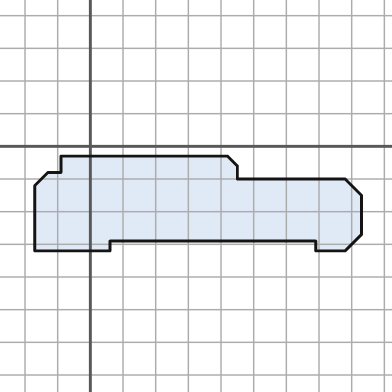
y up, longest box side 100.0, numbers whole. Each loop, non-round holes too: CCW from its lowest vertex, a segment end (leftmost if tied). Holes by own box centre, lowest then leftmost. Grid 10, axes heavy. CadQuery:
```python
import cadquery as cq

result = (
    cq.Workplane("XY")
    .moveTo(-17.0, -32.0)
    .lineTo(6.0, -32.0)
    .lineTo(6.0, -29.0)
    .lineTo(69.0, -29.0)
    .lineTo(69.0, -32.0)
    .lineTo(78.0, -32.0)
    .lineTo(83.0, -27.0)
    .lineTo(83.0, -15.0)
    .lineTo(78.0, -10.0)
    .lineTo(45.0, -10.0)
    .lineTo(45.0, -6.0)
    .lineTo(42.0, -3.0)
    .lineTo(-9.0, -3.0)
    .lineTo(-9.0, -8.0)
    .lineTo(-13.0, -8.0)
    .lineTo(-17.0, -12.0)
    .close()
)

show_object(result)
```